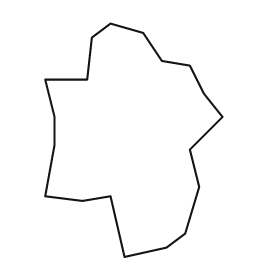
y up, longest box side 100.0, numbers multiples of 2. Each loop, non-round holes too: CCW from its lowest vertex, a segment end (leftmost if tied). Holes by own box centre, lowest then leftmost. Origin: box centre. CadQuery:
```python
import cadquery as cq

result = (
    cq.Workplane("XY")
    .moveTo(-4.0, -50.0)
    .lineTo(14.0, -46.0)
    .lineTo(22.0, -40.0)
    .lineTo(28.0, -20.0)
    .lineTo(24.0, -4.0)
    .lineTo(38.0, 10.0)
    .lineTo(30.0, 20.0)
    .lineTo(24.0, 32.0)
    .lineTo(12.0, 34.0)
    .lineTo(4.0, 46.0)
    .lineTo(-10.0, 50.0)
    .lineTo(-18.0, 44.0)
    .lineTo(-20.0, 26.0)
    .lineTo(-38.0, 26.0)
    .lineTo(-34.0, 10.0)
    .lineTo(-34.0, -2.0)
    .lineTo(-38.0, -24.0)
    .lineTo(-22.0, -26.0)
    .lineTo(-10.0, -24.0)
    .close()
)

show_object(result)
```